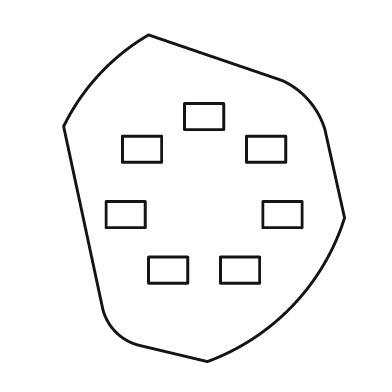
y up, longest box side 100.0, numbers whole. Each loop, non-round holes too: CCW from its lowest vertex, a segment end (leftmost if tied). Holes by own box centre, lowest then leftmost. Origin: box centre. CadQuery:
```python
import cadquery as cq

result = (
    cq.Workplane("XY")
    .moveTo(1.0, -50.0)
    .threePointArc((27.0, -33.0), (43.0, -6.0))
    .lineTo(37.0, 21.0)
    .threePointArc((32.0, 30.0), (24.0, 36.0))
    .lineTo(-17.0, 50.0)
    .threePointArc((-32.0, 38.0), (-43.0, 22.0))
    .lineTo(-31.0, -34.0)
    .threePointArc((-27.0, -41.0), (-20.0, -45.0))
    .close()
    .moveTo(-17.0, -26.0)
    .lineTo(-5.0, -26.0)
    .lineTo(-5.0, -18.0)
    .lineTo(-17.0, -18.0)
    .close()
    .moveTo(5.0, -26.0)
    .lineTo(17.0, -26.0)
    .lineTo(17.0, -18.0)
    .lineTo(5.0, -18.0)
    .close()
    .moveTo(-30.0, -9.0)
    .lineTo(-18.0, -9.0)
    .lineTo(-18.0, -1.0)
    .lineTo(-30.0, -1.0)
    .close()
    .moveTo(18.0, -9.0)
    .lineTo(30.0, -9.0)
    .lineTo(30.0, -1.0)
    .lineTo(18.0, -1.0)
    .close()
    .moveTo(-25.0, 11.0)
    .lineTo(-13.0, 11.0)
    .lineTo(-13.0, 19.0)
    .lineTo(-25.0, 19.0)
    .close()
    .moveTo(13.0, 11.0)
    .lineTo(25.0, 11.0)
    .lineTo(25.0, 19.0)
    .lineTo(13.0, 19.0)
    .close()
    .moveTo(-6.0, 21.0)
    .lineTo(6.0, 21.0)
    .lineTo(6.0, 29.0)
    .lineTo(-6.0, 29.0)
    .close()
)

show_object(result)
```